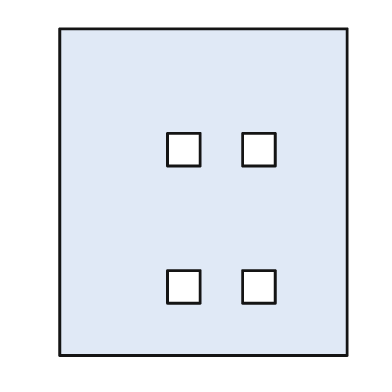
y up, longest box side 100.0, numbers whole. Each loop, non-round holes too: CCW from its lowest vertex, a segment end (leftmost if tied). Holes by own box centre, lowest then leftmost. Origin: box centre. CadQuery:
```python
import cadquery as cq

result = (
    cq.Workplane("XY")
    .moveTo(-44.0, -50.0)
    .lineTo(44.0, -50.0)
    .lineTo(44.0, 50.0)
    .lineTo(-44.0, 50.0)
    .close()
    .moveTo(-11.0, -34.0)
    .lineTo(-1.0, -34.0)
    .lineTo(-1.0, -24.0)
    .lineTo(-11.0, -24.0)
    .close()
    .moveTo(12.0, -34.0)
    .lineTo(22.0, -34.0)
    .lineTo(22.0, -24.0)
    .lineTo(12.0, -24.0)
    .close()
    .moveTo(-11.0, 8.0)
    .lineTo(-1.0, 8.0)
    .lineTo(-1.0, 18.0)
    .lineTo(-11.0, 18.0)
    .close()
    .moveTo(12.0, 8.0)
    .lineTo(22.0, 8.0)
    .lineTo(22.0, 18.0)
    .lineTo(12.0, 18.0)
    .close()
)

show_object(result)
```